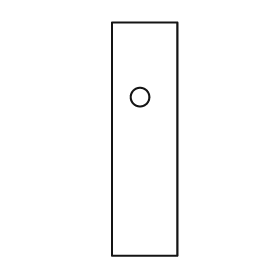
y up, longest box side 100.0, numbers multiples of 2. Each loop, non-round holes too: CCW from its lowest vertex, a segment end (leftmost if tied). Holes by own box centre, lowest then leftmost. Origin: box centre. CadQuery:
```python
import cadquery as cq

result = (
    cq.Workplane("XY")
    .moveTo(-14.0, -50.0)
    .lineTo(14.0, -50.0)
    .lineTo(14.0, 50.0)
    .lineTo(-14.0, 50.0)
    .close()
    .moveTo(-2.0, 18.0)
    .circle(4.0)
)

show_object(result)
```